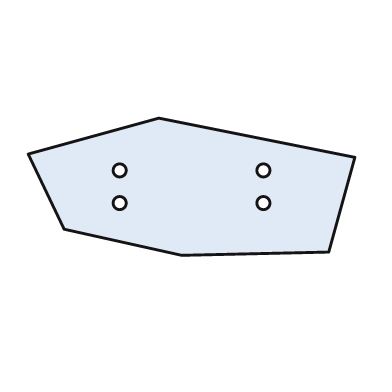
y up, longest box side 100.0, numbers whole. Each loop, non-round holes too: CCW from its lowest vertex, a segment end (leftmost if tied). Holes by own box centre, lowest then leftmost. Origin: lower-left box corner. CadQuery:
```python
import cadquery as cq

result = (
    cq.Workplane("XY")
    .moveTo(47.0, 0.0)
    .lineTo(92.0, 1.0)
    .lineTo(100.0, 30.0)
    .lineTo(40.0, 42.0)
    .lineTo(0.0, 31.0)
    .lineTo(11.0, 8.0)
    .close()
    .moveTo(28.0, 16.0)
    .circle(2.0)
    .moveTo(72.0, 16.0)
    .circle(2.0)
    .moveTo(28.0, 26.0)
    .circle(2.0)
    .moveTo(72.0, 26.0)
    .circle(2.0)
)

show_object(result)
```